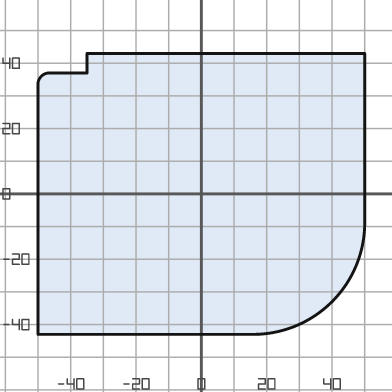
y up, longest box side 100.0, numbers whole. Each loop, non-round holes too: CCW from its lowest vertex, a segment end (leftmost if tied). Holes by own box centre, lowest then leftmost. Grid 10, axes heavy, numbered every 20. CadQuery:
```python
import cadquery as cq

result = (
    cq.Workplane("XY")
    .moveTo(-50.0, -43.0)
    .lineTo(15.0, -43.0)
    .threePointArc((40.0, -33.0), (50.0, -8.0))
    .lineTo(50.0, 43.0)
    .lineTo(-35.0, 43.0)
    .lineTo(-35.0, 37.0)
    .lineTo(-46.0, 37.0)
    .threePointArc((-49.0, 36.0), (-50.0, 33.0))
    .close()
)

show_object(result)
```